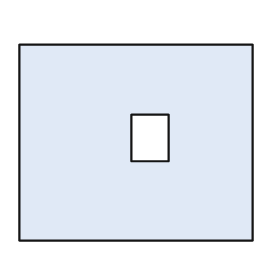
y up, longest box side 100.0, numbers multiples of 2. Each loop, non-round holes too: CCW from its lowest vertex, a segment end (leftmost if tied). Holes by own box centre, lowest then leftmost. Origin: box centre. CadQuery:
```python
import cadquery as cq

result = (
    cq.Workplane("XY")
    .moveTo(-50.0, -42.0)
    .lineTo(50.0, -42.0)
    .lineTo(50.0, 42.0)
    .lineTo(-50.0, 42.0)
    .close()
    .moveTo(-2.0, -8.0)
    .lineTo(14.0, -8.0)
    .lineTo(14.0, 12.0)
    .lineTo(-2.0, 12.0)
    .close()
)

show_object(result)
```